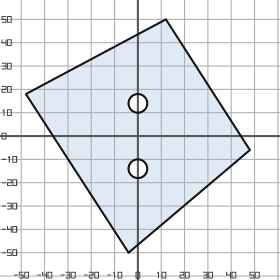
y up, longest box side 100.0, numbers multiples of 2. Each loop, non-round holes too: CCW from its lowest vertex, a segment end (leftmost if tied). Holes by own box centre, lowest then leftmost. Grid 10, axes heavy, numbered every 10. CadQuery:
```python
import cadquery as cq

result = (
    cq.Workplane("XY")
    .moveTo(-4.0, -50.0)
    .lineTo(48.0, -6.0)
    .lineTo(12.0, 50.0)
    .lineTo(-48.0, 18.0)
    .close()
    .moveTo(0.0, -14.0)
    .circle(4.0)
    .moveTo(0.0, 14.0)
    .circle(4.0)
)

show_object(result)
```